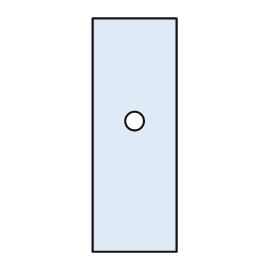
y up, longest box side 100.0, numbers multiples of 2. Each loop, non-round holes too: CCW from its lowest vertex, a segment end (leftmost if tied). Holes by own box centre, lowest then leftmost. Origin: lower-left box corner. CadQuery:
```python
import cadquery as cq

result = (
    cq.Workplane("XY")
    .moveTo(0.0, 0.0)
    .lineTo(36.0, 0.0)
    .lineTo(36.0, 100.0)
    .lineTo(0.0, 100.0)
    .close()
    .moveTo(18.0, 56.0)
    .circle(4.0)
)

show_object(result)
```